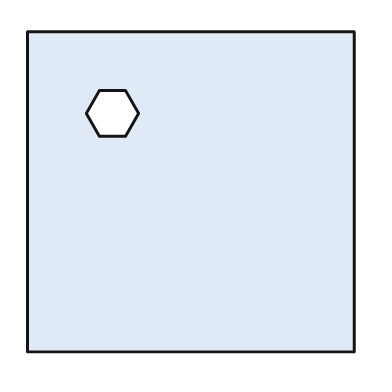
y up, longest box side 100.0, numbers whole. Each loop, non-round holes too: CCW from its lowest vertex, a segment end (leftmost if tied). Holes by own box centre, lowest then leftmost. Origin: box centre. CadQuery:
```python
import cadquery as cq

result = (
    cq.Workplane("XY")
    .moveTo(-50.0, -49.0)
    .lineTo(50.0, -49.0)
    .lineTo(50.0, 49.0)
    .lineTo(-50.0, 49.0)
    .close()
    .moveTo(-28.0, 17.0)
    .lineTo(-20.0, 17.0)
    .lineTo(-16.0, 24.0)
    .lineTo(-20.0, 31.0)
    .lineTo(-28.0, 31.0)
    .lineTo(-32.0, 24.0)
    .close()
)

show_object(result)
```